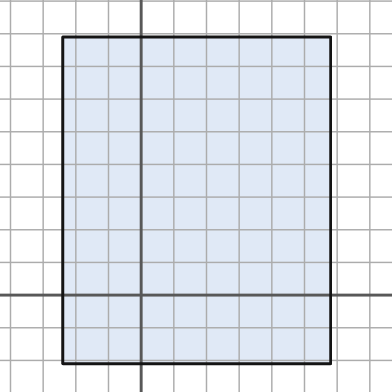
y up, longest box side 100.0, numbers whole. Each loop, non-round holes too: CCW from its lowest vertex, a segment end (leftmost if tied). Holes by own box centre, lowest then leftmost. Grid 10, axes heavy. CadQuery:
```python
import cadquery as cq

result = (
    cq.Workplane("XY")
    .moveTo(-24.0, -21.0)
    .lineTo(58.0, -21.0)
    .lineTo(58.0, 79.0)
    .lineTo(-24.0, 79.0)
    .close()
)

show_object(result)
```